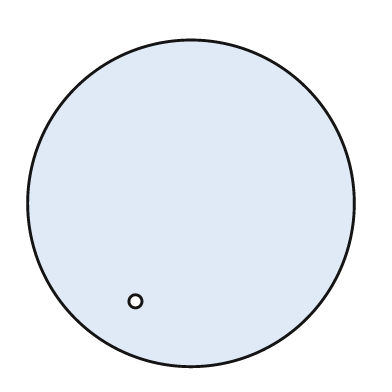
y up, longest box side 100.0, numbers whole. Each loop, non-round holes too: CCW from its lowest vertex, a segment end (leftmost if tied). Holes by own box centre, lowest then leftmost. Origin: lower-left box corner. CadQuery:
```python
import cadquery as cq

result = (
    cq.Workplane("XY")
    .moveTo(50.0, 50.0)
    .circle(50.0)
    .moveTo(33.0, 20.0)
    .circle(2.0)
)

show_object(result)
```